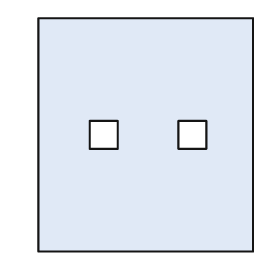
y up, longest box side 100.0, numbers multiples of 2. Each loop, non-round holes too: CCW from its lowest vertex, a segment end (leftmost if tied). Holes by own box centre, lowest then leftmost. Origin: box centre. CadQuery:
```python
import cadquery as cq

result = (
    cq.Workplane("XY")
    .moveTo(-46.0, -50.0)
    .lineTo(46.0, -50.0)
    .lineTo(46.0, 50.0)
    .lineTo(-46.0, 50.0)
    .close()
    .moveTo(-24.0, -6.0)
    .lineTo(-12.0, -6.0)
    .lineTo(-12.0, 6.0)
    .lineTo(-24.0, 6.0)
    .close()
    .moveTo(14.0, -6.0)
    .lineTo(26.0, -6.0)
    .lineTo(26.0, 6.0)
    .lineTo(14.0, 6.0)
    .close()
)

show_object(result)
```